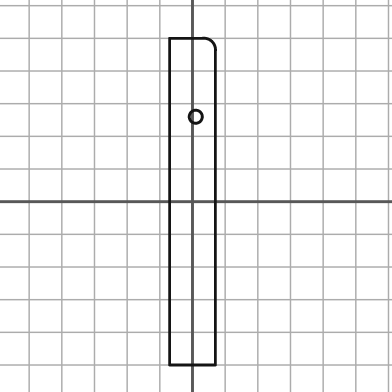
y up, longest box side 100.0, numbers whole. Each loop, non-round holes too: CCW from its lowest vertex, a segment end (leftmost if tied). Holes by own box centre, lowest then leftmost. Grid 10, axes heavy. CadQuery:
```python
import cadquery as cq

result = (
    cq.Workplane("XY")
    .moveTo(-7.0, -50.0)
    .lineTo(7.0, -50.0)
    .lineTo(7.0, 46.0)
    .threePointArc((6.0, 49.0), (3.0, 50.0))
    .lineTo(-7.0, 50.0)
    .close()
    .moveTo(1.0, 26.0)
    .circle(2.0)
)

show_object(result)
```